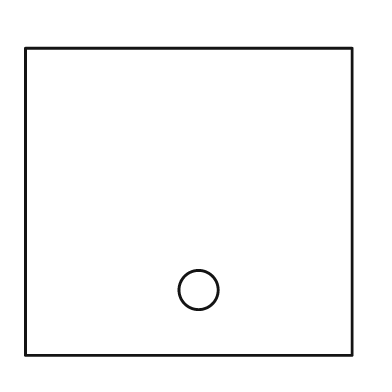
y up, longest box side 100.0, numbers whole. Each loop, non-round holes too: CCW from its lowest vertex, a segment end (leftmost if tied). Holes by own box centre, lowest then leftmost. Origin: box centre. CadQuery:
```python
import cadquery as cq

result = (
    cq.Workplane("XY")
    .moveTo(-50.0, -47.0)
    .lineTo(50.0, -47.0)
    .lineTo(50.0, 47.0)
    .lineTo(-50.0, 47.0)
    .close()
    .moveTo(3.0, -27.0)
    .circle(6.0)
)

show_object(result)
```